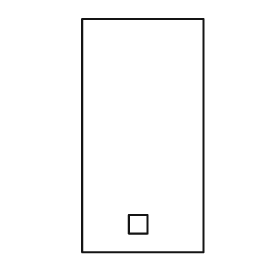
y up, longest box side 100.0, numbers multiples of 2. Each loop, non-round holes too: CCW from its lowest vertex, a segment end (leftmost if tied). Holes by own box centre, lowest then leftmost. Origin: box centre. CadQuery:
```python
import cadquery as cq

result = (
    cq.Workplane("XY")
    .moveTo(-26.0, -50.0)
    .lineTo(26.0, -50.0)
    .lineTo(26.0, 50.0)
    .lineTo(-26.0, 50.0)
    .close()
    .moveTo(-6.0, -42.0)
    .lineTo(2.0, -42.0)
    .lineTo(2.0, -34.0)
    .lineTo(-6.0, -34.0)
    .close()
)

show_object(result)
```